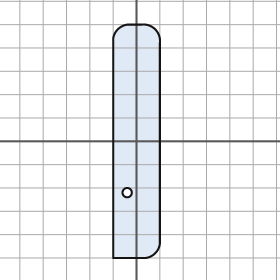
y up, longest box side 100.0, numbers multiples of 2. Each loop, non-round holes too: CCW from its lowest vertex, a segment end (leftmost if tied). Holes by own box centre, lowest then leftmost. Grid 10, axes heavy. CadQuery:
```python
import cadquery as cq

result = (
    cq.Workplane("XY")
    .moveTo(-10.0, -50.0)
    .lineTo(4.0, -50.0)
    .threePointArc((8.0, -48.0), (10.0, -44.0))
    .lineTo(10.0, 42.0)
    .threePointArc((8.0, 48.0), (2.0, 50.0))
    .lineTo(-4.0, 50.0)
    .threePointArc((-8.0, 48.0), (-10.0, 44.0))
    .close()
    .moveTo(-4.0, -22.0)
    .circle(2.0)
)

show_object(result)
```